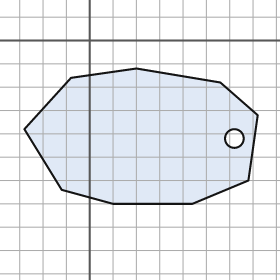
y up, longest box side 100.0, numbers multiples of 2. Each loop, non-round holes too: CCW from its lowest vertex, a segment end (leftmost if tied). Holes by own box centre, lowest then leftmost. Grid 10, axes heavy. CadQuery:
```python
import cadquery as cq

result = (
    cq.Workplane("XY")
    .moveTo(10.0, -70.0)
    .lineTo(44.0, -70.0)
    .lineTo(68.0, -60.0)
    .lineTo(72.0, -32.0)
    .lineTo(56.0, -18.0)
    .lineTo(20.0, -12.0)
    .lineTo(-8.0, -16.0)
    .lineTo(-28.0, -38.0)
    .lineTo(-12.0, -64.0)
    .close()
    .moveTo(62.0, -42.0)
    .circle(4.0)
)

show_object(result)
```